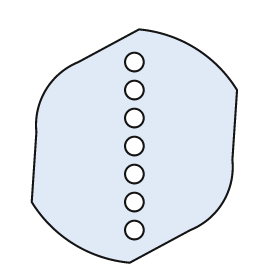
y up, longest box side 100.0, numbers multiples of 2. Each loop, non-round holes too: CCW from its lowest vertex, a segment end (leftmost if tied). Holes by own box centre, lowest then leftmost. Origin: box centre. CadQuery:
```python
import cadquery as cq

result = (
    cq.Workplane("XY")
    .moveTo(-2.0, -50.0)
    .lineTo(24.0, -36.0)
    .threePointArc((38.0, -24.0), (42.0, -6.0))
    .lineTo(44.0, 24.0)
    .threePointArc((26.0, 42.0), (2.0, 50.0))
    .lineTo(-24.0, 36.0)
    .threePointArc((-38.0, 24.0), (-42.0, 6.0))
    .lineTo(-44.0, -24.0)
    .threePointArc((-26.0, -42.0), (-2.0, -50.0))
    .close()
    .moveTo(0.0, -36.0)
    .circle(4.0)
    .moveTo(0.0, -24.0)
    .circle(4.0)
    .moveTo(0.0, -12.0)
    .circle(4.0)
    .moveTo(0.0, 0.0)
    .circle(4.0)
    .moveTo(0.0, 12.0)
    .circle(4.0)
    .moveTo(0.0, 24.0)
    .circle(4.0)
    .moveTo(0.0, 36.0)
    .circle(4.0)
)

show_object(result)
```